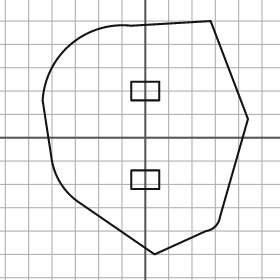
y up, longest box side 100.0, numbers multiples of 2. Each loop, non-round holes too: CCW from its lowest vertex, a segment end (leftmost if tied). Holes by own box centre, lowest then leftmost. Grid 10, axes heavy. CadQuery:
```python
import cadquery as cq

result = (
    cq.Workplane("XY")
    .moveTo(4.0, -50.0)
    .lineTo(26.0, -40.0)
    .threePointArc((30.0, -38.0), (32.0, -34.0))
    .lineTo(44.0, 8.0)
    .lineTo(28.0, 50.0)
    .lineTo(-6.0, 48.0)
    .threePointArc((-32.0, 40.0), (-44.0, 16.0))
    .lineTo(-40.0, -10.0)
    .threePointArc((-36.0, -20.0), (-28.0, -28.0))
    .close()
    .moveTo(-6.0, -22.0)
    .lineTo(6.0, -22.0)
    .lineTo(6.0, -14.0)
    .lineTo(-6.0, -14.0)
    .close()
    .moveTo(-6.0, 16.0)
    .lineTo(6.0, 16.0)
    .lineTo(6.0, 24.0)
    .lineTo(-6.0, 24.0)
    .close()
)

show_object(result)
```